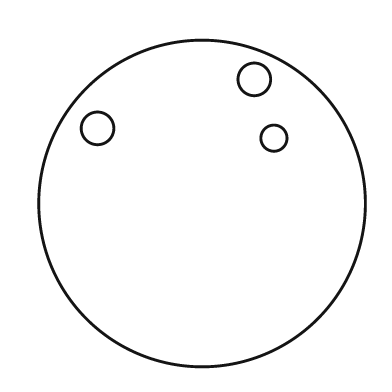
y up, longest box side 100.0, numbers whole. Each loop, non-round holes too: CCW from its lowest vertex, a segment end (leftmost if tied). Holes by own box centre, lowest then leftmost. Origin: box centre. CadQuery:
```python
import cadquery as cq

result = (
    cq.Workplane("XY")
    .moveTo(0.0, 0.0)
    .circle(50.0)
    .moveTo(22.0, 20.0)
    .circle(4.0)
    .moveTo(-32.0, 23.0)
    .circle(5.0)
    .moveTo(16.0, 38.0)
    .circle(5.0)
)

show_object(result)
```